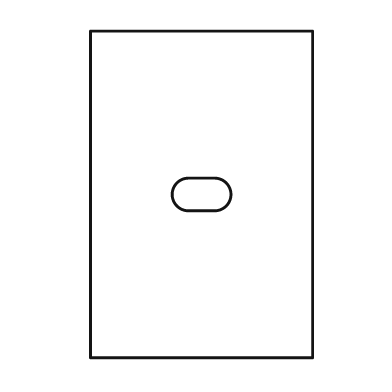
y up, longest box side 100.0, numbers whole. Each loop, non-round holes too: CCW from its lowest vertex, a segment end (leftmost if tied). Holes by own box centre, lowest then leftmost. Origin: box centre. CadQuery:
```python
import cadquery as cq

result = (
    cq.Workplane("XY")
    .moveTo(-34.0, -50.0)
    .lineTo(34.0, -50.0)
    .lineTo(34.0, 50.0)
    .lineTo(-34.0, 50.0)
    .close()
    .moveTo(-4.0, -5.0)
    .lineTo(4.0, -5.0)
    .threePointArc((9.0, 0.0), (4.0, 5.0))
    .lineTo(-4.0, 5.0)
    .threePointArc((-9.0, 0.0), (-4.0, -5.0))
    .close()
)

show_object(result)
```